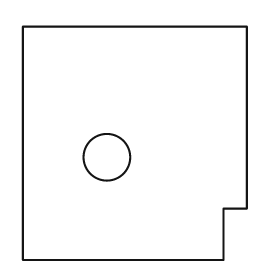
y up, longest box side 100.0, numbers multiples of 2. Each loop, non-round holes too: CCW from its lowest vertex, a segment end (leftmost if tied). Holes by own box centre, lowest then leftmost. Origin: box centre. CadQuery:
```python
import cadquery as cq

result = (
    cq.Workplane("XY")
    .moveTo(-48.0, -50.0)
    .lineTo(38.0, -50.0)
    .lineTo(38.0, -28.0)
    .lineTo(48.0, -28.0)
    .lineTo(48.0, 50.0)
    .lineTo(-48.0, 50.0)
    .close()
    .moveTo(-12.0, -6.0)
    .circle(10.0)
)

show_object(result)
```